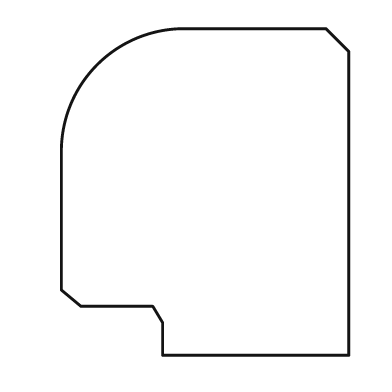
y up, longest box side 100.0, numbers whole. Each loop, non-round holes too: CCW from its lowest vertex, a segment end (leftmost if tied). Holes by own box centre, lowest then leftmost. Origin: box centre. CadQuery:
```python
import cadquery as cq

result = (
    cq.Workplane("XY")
    .moveTo(-13.0, -50.0)
    .lineTo(44.0, -50.0)
    .lineTo(44.0, 43.0)
    .lineTo(37.0, 50.0)
    .lineTo(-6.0, 50.0)
    .threePointArc((-33.0, 39.0), (-44.0, 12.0))
    .lineTo(-44.0, -30.0)
    .lineTo(-38.0, -35.0)
    .lineTo(-16.0, -35.0)
    .lineTo(-13.0, -40.0)
    .close()
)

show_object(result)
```